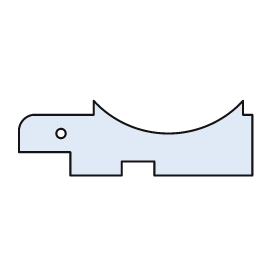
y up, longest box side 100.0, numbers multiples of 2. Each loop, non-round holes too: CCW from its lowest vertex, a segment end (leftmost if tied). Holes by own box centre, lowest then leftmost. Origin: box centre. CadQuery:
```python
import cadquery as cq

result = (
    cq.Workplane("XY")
    .moveTo(-28.0, -16.0)
    .lineTo(-6.0, -16.0)
    .lineTo(-6.0, -10.0)
    .lineTo(8.0, -10.0)
    .lineTo(8.0, -16.0)
    .lineTo(50.0, -16.0)
    .lineTo(50.0, 10.0)
    .lineTo(46.0, 10.0)
    .lineTo(46.0, 16.0)
    .threePointArc((14.0, 2.0), (-18.0, 16.0))
    .lineTo(-18.0, 10.0)
    .lineTo(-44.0, 10.0)
    .threePointArc((-48.0, 8.0), (-50.0, 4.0))
    .lineTo(-50.0, -6.0)
    .lineTo(-28.0, -6.0)
    .close()
    .moveTo(-32.0, 2.0)
    .circle(2.0)
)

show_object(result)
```